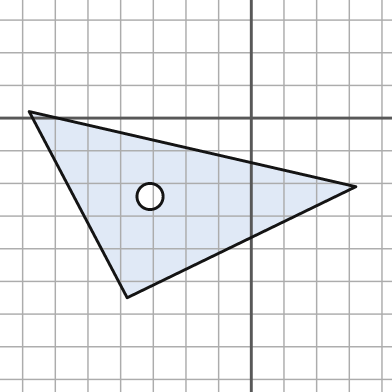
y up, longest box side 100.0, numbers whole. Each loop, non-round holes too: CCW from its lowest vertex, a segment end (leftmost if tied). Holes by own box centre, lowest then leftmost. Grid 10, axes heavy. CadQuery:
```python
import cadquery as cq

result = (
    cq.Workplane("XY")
    .moveTo(-38.0, -55.0)
    .lineTo(32.0, -21.0)
    .lineTo(-68.0, 2.0)
    .close()
    .moveTo(-31.0, -24.0)
    .circle(4.0)
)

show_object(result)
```